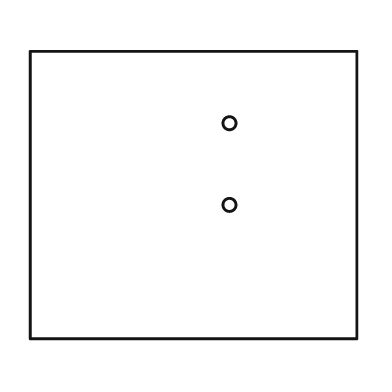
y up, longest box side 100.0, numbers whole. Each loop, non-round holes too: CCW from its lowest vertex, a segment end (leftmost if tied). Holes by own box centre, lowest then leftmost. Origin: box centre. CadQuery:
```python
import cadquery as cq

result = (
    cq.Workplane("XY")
    .moveTo(-50.0, -44.0)
    .lineTo(50.0, -44.0)
    .lineTo(50.0, 44.0)
    .lineTo(-50.0, 44.0)
    .close()
    .moveTo(11.0, -3.0)
    .circle(2.0)
    .moveTo(11.0, 22.0)
    .circle(2.0)
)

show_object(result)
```